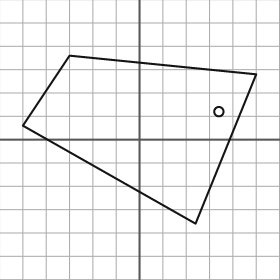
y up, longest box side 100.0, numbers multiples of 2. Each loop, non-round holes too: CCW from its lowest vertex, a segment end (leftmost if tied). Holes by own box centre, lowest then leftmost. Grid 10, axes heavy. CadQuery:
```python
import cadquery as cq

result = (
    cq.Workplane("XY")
    .moveTo(24.0, -36.0)
    .lineTo(50.0, 28.0)
    .lineTo(-30.0, 36.0)
    .lineTo(-50.0, 6.0)
    .close()
    .moveTo(34.0, 12.0)
    .circle(2.0)
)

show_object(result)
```